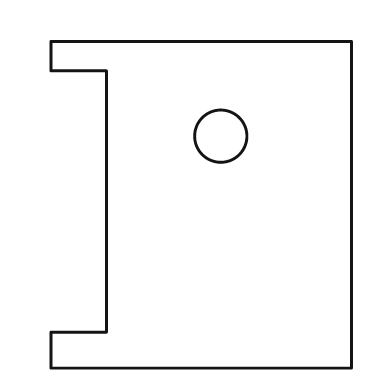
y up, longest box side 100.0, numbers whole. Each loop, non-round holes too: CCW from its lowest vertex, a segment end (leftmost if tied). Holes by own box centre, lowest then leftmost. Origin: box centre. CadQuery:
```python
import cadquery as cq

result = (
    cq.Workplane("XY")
    .moveTo(-46.0, -50.0)
    .lineTo(46.0, -50.0)
    .lineTo(46.0, 50.0)
    .lineTo(-46.0, 50.0)
    .lineTo(-46.0, 41.0)
    .lineTo(-29.0, 41.0)
    .lineTo(-29.0, -39.0)
    .lineTo(-46.0, -39.0)
    .close()
    .moveTo(6.0, 21.0)
    .circle(8.0)
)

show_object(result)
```